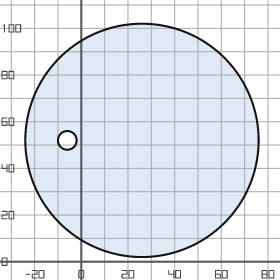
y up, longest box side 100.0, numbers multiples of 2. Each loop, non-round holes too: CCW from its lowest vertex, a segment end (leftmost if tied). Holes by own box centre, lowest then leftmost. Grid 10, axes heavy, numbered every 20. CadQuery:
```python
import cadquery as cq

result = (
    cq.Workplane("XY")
    .moveTo(26.0, 52.0)
    .circle(50.0)
    .moveTo(-6.0, 52.0)
    .circle(4.0)
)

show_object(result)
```